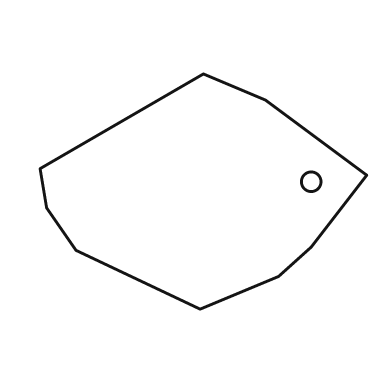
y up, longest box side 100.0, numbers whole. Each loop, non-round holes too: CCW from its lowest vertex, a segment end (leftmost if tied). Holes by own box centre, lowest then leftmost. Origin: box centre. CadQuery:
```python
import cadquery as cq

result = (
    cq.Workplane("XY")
    .moveTo(-1.0, -36.0)
    .lineTo(23.0, -26.0)
    .lineTo(33.0, -17.0)
    .lineTo(50.0, 5.0)
    .lineTo(19.0, 28.0)
    .lineTo(0.0, 36.0)
    .lineTo(-50.0, 7.0)
    .lineTo(-48.0, -5.0)
    .lineTo(-39.0, -18.0)
    .close()
    .moveTo(33.0, 3.0)
    .circle(3.0)
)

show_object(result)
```